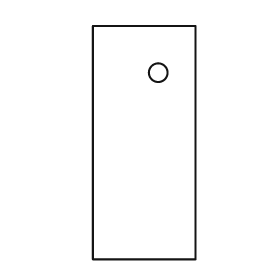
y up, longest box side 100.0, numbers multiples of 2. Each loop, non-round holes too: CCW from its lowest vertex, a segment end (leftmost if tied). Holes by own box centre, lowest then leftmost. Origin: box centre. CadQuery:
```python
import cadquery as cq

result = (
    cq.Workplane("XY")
    .moveTo(-22.0, -50.0)
    .lineTo(22.0, -50.0)
    .lineTo(22.0, 50.0)
    .lineTo(-22.0, 50.0)
    .close()
    .moveTo(6.0, 30.0)
    .circle(4.0)
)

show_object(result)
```